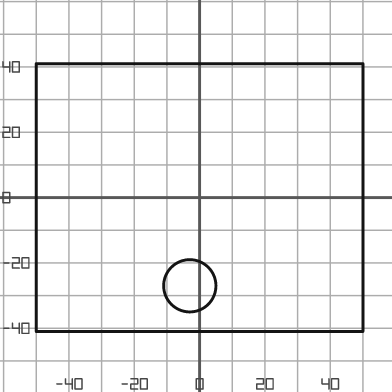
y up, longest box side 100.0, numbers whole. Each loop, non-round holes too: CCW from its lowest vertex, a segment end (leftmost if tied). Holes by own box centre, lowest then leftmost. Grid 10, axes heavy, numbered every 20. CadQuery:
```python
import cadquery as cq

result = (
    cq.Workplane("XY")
    .moveTo(-50.0, -41.0)
    .lineTo(50.0, -41.0)
    .lineTo(50.0, 41.0)
    .lineTo(-50.0, 41.0)
    .close()
    .moveTo(-3.0, -27.0)
    .circle(8.0)
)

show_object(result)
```